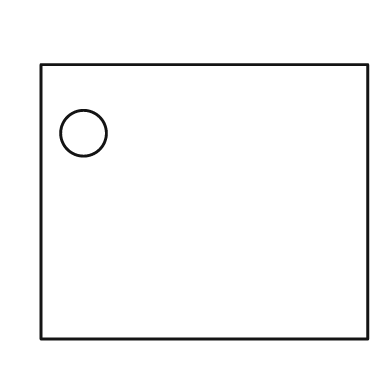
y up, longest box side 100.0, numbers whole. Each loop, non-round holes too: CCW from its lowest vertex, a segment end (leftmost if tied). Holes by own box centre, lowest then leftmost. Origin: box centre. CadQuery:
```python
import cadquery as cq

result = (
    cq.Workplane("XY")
    .moveTo(-50.0, -42.0)
    .lineTo(50.0, -42.0)
    .lineTo(50.0, 42.0)
    .lineTo(-50.0, 42.0)
    .close()
    .moveTo(-37.0, 21.0)
    .circle(7.0)
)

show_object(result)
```